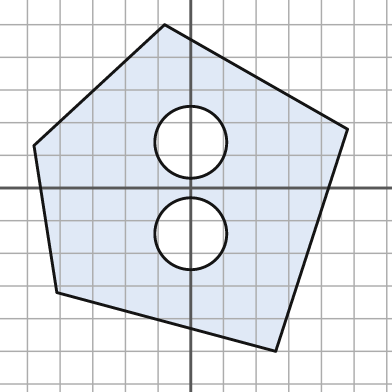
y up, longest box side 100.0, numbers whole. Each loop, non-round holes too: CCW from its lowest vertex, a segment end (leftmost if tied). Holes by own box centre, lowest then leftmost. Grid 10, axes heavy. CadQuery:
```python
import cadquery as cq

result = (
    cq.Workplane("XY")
    .moveTo(26.0, -50.0)
    .lineTo(48.0, 18.0)
    .lineTo(-8.0, 50.0)
    .lineTo(-48.0, 13.0)
    .lineTo(-41.0, -32.0)
    .close()
    .moveTo(0.0, -14.0)
    .circle(11.0)
    .moveTo(0.0, 14.0)
    .circle(11.0)
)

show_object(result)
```